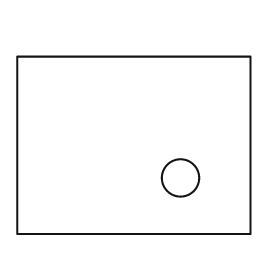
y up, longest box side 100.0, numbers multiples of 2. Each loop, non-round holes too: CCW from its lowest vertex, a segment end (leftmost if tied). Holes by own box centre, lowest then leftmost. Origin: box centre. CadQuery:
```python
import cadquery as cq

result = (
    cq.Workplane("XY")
    .moveTo(-50.0, -38.0)
    .lineTo(50.0, -38.0)
    .lineTo(50.0, 38.0)
    .lineTo(-50.0, 38.0)
    .close()
    .moveTo(20.0, -14.0)
    .circle(8.0)
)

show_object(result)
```